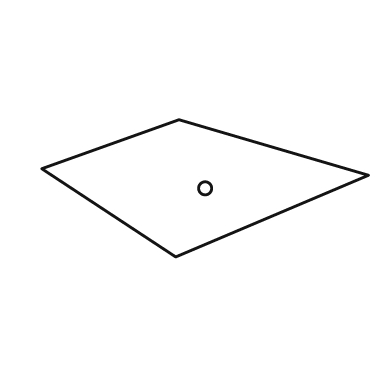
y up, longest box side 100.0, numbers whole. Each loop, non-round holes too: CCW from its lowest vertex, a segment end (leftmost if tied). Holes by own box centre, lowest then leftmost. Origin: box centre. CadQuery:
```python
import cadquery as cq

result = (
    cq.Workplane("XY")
    .moveTo(-9.0, -21.0)
    .lineTo(50.0, 4.0)
    .lineTo(-8.0, 21.0)
    .lineTo(-50.0, 6.0)
    .close()
    .moveTo(0.0, 0.0)
    .circle(2.0)
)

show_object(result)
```